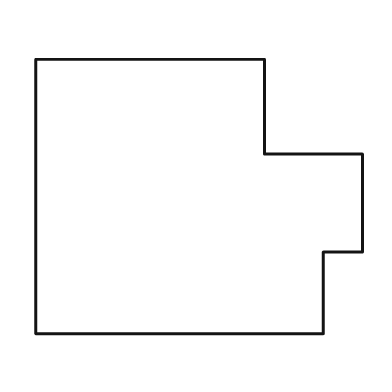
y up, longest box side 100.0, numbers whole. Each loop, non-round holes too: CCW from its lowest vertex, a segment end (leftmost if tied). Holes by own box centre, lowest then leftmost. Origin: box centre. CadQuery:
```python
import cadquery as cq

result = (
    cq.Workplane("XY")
    .moveTo(-50.0, -42.0)
    .lineTo(38.0, -42.0)
    .lineTo(38.0, -17.0)
    .lineTo(50.0, -17.0)
    .lineTo(50.0, 13.0)
    .lineTo(20.0, 13.0)
    .lineTo(20.0, 42.0)
    .lineTo(-50.0, 42.0)
    .close()
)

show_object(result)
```